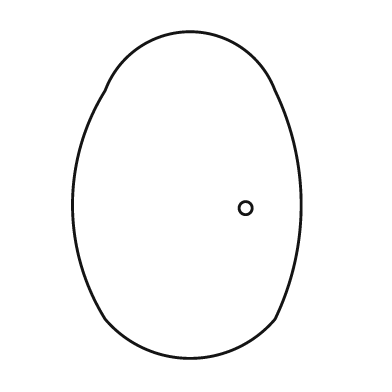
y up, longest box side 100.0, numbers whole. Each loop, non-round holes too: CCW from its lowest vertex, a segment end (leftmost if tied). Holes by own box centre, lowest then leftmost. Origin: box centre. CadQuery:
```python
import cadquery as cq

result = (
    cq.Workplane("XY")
    .moveTo(-25.0, -38.0)
    .threePointArc((1.0, -50.0), (27.0, -38.0))
    .threePointArc((35.0, -3.0), (27.0, 32.0))
    .threePointArc((1.0, 50.0), (-25.0, 32.0))
    .threePointArc((-35.0, -3.0), (-25.0, -38.0))
    .close()
    .moveTo(18.0, -4.0)
    .circle(2.0)
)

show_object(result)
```